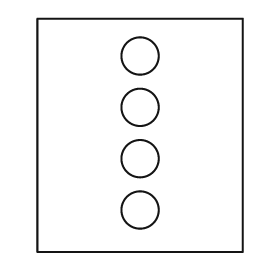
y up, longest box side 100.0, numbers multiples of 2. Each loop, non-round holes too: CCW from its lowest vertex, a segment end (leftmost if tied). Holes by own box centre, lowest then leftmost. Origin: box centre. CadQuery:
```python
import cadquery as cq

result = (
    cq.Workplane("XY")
    .moveTo(-44.0, -50.0)
    .lineTo(44.0, -50.0)
    .lineTo(44.0, 50.0)
    .lineTo(-44.0, 50.0)
    .close()
    .moveTo(0.0, -32.0)
    .circle(8.0)
    .moveTo(0.0, -10.0)
    .circle(8.0)
    .moveTo(0.0, 12.0)
    .circle(8.0)
    .moveTo(0.0, 34.0)
    .circle(8.0)
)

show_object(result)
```